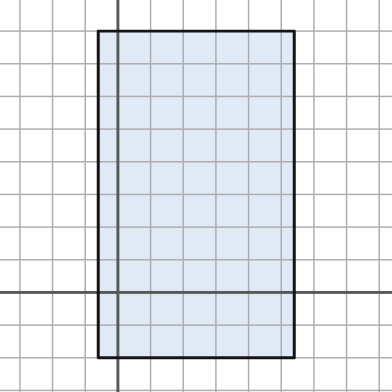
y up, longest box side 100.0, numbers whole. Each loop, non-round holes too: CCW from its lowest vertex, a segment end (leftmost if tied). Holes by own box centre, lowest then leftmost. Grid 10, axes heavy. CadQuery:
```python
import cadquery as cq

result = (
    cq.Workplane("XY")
    .moveTo(-6.0, -20.0)
    .lineTo(54.0, -20.0)
    .lineTo(54.0, 80.0)
    .lineTo(-6.0, 80.0)
    .close()
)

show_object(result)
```